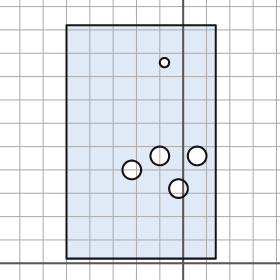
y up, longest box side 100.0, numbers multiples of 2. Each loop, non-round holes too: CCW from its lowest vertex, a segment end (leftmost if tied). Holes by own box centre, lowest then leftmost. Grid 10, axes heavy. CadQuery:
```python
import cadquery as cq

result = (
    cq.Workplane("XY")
    .moveTo(-50.0, 2.0)
    .lineTo(14.0, 2.0)
    .lineTo(14.0, 102.0)
    .lineTo(-50.0, 102.0)
    .close()
    .moveTo(-2.0, 32.0)
    .circle(4.0)
    .moveTo(-22.0, 40.0)
    .circle(4.0)
    .moveTo(-10.0, 46.0)
    .circle(4.0)
    .moveTo(6.0, 46.0)
    .circle(4.0)
    .moveTo(-8.0, 86.0)
    .circle(2.0)
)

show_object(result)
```